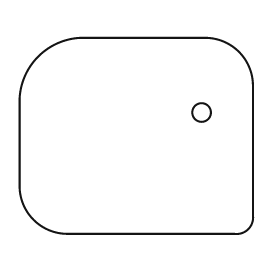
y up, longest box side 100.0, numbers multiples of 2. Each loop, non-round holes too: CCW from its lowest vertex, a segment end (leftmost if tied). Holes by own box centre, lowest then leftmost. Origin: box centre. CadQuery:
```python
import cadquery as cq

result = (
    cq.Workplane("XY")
    .moveTo(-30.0, -42.0)
    .lineTo(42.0, -42.0)
    .threePointArc((48.0, -40.0), (50.0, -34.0))
    .lineTo(50.0, 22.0)
    .threePointArc((44.0, 36.0), (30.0, 42.0))
    .lineTo(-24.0, 42.0)
    .threePointArc((-42.0, 34.0), (-50.0, 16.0))
    .lineTo(-50.0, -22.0)
    .threePointArc((-44.0, -36.0), (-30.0, -42.0))
    .close()
    .moveTo(28.0, 10.0)
    .circle(4.0)
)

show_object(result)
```